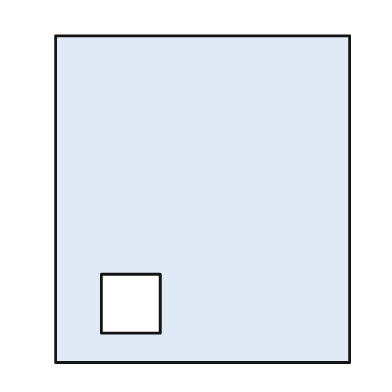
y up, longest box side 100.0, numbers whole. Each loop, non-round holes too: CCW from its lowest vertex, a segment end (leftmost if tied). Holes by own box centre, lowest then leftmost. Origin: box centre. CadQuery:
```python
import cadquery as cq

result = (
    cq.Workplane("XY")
    .moveTo(-45.0, -50.0)
    .lineTo(45.0, -50.0)
    .lineTo(45.0, 50.0)
    .lineTo(-45.0, 50.0)
    .close()
    .moveTo(-31.0, -41.0)
    .lineTo(-13.0, -41.0)
    .lineTo(-13.0, -23.0)
    .lineTo(-31.0, -23.0)
    .close()
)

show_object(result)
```